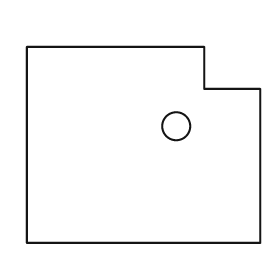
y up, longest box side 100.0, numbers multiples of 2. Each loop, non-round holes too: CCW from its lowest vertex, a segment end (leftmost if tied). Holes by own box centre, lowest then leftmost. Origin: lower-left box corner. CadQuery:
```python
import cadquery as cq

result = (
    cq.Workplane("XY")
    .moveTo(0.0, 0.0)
    .lineTo(100.0, 0.0)
    .lineTo(100.0, 66.0)
    .lineTo(76.0, 66.0)
    .lineTo(76.0, 84.0)
    .lineTo(0.0, 84.0)
    .close()
    .moveTo(64.0, 50.0)
    .circle(6.0)
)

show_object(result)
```